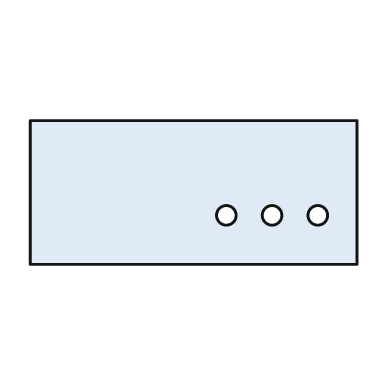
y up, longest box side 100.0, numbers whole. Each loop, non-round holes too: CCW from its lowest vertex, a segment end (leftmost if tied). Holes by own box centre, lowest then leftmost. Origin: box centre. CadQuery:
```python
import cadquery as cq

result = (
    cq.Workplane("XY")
    .moveTo(-50.0, -22.0)
    .lineTo(50.0, -22.0)
    .lineTo(50.0, 22.0)
    .lineTo(-50.0, 22.0)
    .close()
    .moveTo(10.0, -7.0)
    .circle(3.0)
    .moveTo(24.0, -7.0)
    .circle(3.0)
    .moveTo(38.0, -7.0)
    .circle(3.0)
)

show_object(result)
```